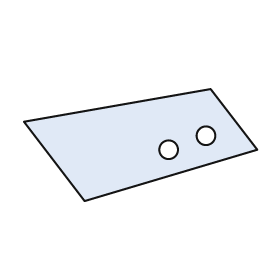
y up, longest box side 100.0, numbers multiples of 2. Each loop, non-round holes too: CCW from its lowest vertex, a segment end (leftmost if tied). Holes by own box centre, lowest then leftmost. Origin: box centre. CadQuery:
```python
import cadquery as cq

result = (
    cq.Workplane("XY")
    .moveTo(-24.0, -24.0)
    .lineTo(50.0, -2.0)
    .lineTo(30.0, 24.0)
    .lineTo(-50.0, 10.0)
    .close()
    .moveTo(12.0, -2.0)
    .circle(4.0)
    .moveTo(28.0, 4.0)
    .circle(4.0)
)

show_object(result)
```